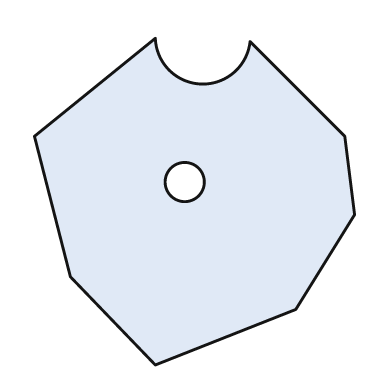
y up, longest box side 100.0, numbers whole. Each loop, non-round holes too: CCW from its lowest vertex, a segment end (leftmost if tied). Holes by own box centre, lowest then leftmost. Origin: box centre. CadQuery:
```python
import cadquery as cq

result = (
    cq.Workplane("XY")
    .moveTo(-12.0, -50.0)
    .lineTo(31.0, -33.0)
    .lineTo(49.0, -4.0)
    .lineTo(46.0, 20.0)
    .lineTo(17.0, 49.0)
    .threePointArc((2.0, 36.0), (-12.0, 50.0))
    .lineTo(-49.0, 20.0)
    .lineTo(-38.0, -23.0)
    .close()
    .moveTo(-3.0, 6.0)
    .circle(6.0)
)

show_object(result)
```